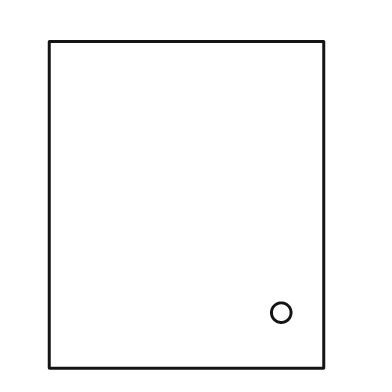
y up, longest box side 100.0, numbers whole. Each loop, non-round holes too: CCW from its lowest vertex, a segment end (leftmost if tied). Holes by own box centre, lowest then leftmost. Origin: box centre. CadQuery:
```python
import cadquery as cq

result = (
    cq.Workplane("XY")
    .moveTo(-42.0, -50.0)
    .lineTo(42.0, -50.0)
    .lineTo(42.0, 50.0)
    .lineTo(-42.0, 50.0)
    .close()
    .moveTo(29.0, -33.0)
    .circle(3.0)
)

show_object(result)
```